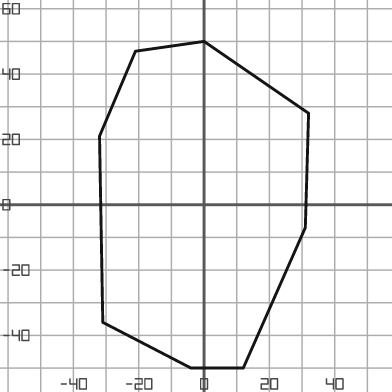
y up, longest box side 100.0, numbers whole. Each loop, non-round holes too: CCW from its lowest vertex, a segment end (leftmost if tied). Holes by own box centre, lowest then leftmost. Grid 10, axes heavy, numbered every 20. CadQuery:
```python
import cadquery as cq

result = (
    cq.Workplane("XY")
    .moveTo(-4.0, -50.0)
    .lineTo(12.0, -50.0)
    .lineTo(31.0, -7.0)
    .lineTo(32.0, 28.0)
    .lineTo(0.0, 50.0)
    .lineTo(-21.0, 47.0)
    .lineTo(-32.0, 21.0)
    .lineTo(-31.0, -36.0)
    .close()
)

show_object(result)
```